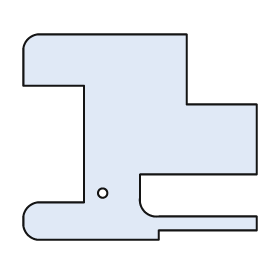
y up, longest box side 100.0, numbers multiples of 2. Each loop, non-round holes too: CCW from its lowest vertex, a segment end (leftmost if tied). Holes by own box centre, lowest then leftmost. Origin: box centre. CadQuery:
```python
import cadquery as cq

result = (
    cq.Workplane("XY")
    .moveTo(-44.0, -44.0)
    .lineTo(8.0, -44.0)
    .lineTo(8.0, -40.0)
    .lineTo(50.0, -40.0)
    .lineTo(50.0, -34.0)
    .lineTo(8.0, -34.0)
    .threePointArc((2.0, -32.0), (0.0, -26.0))
    .lineTo(0.0, -16.0)
    .lineTo(50.0, -16.0)
    .lineTo(50.0, 14.0)
    .lineTo(20.0, 14.0)
    .lineTo(20.0, 44.0)
    .lineTo(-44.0, 44.0)
    .threePointArc((-48.0, 42.0), (-50.0, 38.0))
    .lineTo(-50.0, 22.0)
    .lineTo(-24.0, 22.0)
    .lineTo(-24.0, -28.0)
    .lineTo(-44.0, -28.0)
    .threePointArc((-48.0, -30.0), (-50.0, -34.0))
    .lineTo(-50.0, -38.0)
    .threePointArc((-48.0, -42.0), (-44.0, -44.0))
    .close()
    .moveTo(-16.0, -24.0)
    .circle(2.0)
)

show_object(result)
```